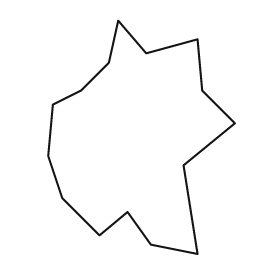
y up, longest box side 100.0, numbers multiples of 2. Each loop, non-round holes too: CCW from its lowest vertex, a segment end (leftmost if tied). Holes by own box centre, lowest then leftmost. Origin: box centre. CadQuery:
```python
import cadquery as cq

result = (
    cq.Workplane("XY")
    .moveTo(24.0, -50.0)
    .lineTo(18.0, -12.0)
    .lineTo(40.0, 6.0)
    .lineTo(26.0, 20.0)
    .lineTo(24.0, 42.0)
    .lineTo(2.0, 36.0)
    .lineTo(-10.0, 50.0)
    .lineTo(-14.0, 32.0)
    .lineTo(-26.0, 20.0)
    .lineTo(-38.0, 14.0)
    .lineTo(-40.0, -8.0)
    .lineTo(-34.0, -26.0)
    .lineTo(-18.0, -42.0)
    .lineTo(-6.0, -32.0)
    .lineTo(4.0, -46.0)
    .close()
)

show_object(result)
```